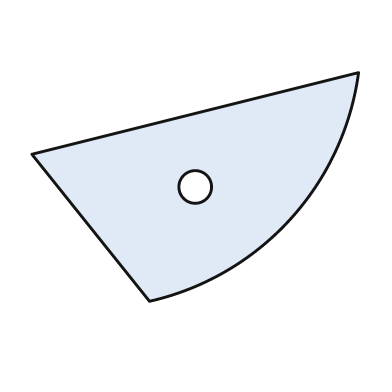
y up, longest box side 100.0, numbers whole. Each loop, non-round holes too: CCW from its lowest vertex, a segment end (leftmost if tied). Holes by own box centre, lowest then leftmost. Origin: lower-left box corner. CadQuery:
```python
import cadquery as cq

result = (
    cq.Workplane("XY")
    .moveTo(36.0, 0.0)
    .threePointArc((79.0, 25.0), (100.0, 70.0))
    .lineTo(0.0, 45.0)
    .close()
    .moveTo(50.0, 35.0)
    .circle(5.0)
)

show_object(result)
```